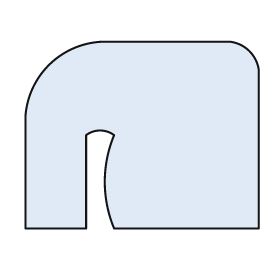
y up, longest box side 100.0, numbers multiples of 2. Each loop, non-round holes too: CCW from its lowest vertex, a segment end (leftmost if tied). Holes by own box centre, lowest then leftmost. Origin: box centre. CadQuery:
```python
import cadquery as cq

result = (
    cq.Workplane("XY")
    .moveTo(-50.0, -40.0)
    .lineTo(-24.0, -40.0)
    .lineTo(-24.0, 0.0)
    .threePointArc((-18.0, 2.0), (-12.0, 0.0))
    .threePointArc((-16.0, -20.0), (-12.0, -40.0))
    .lineTo(50.0, -40.0)
    .lineTo(50.0, 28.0)
    .threePointArc((46.0, 36.0), (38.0, 40.0))
    .lineTo(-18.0, 40.0)
    .threePointArc((-40.0, 30.0), (-50.0, 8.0))
    .close()
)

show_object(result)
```